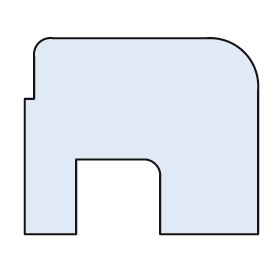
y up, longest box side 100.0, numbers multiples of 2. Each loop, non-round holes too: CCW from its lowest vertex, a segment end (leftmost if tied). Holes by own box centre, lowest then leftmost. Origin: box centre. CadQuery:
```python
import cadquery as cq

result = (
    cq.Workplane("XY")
    .moveTo(-50.0, -42.0)
    .lineTo(-28.0, -42.0)
    .lineTo(-28.0, -10.0)
    .lineTo(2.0, -10.0)
    .threePointArc((6.0, -12.0), (8.0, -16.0))
    .lineTo(8.0, -42.0)
    .lineTo(50.0, -42.0)
    .lineTo(50.0, 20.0)
    .threePointArc((44.0, 36.0), (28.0, 42.0))
    .lineTo(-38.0, 42.0)
    .threePointArc((-44.0, 40.0), (-46.0, 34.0))
    .lineTo(-46.0, 16.0)
    .lineTo(-50.0, 16.0)
    .close()
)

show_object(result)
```